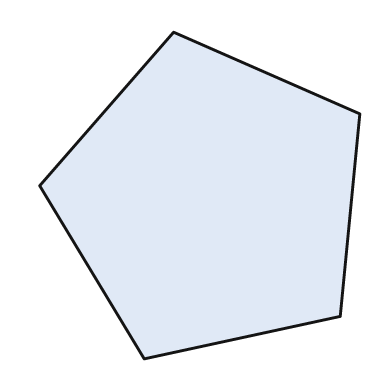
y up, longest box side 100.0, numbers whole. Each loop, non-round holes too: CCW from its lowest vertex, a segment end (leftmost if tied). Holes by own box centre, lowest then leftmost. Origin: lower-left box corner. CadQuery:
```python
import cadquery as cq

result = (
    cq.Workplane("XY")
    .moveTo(32.0, 0.0)
    .lineTo(92.0, 13.0)
    .lineTo(98.0, 75.0)
    .lineTo(41.0, 100.0)
    .lineTo(0.0, 53.0)
    .close()
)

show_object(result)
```